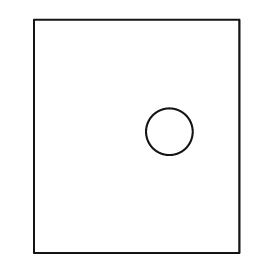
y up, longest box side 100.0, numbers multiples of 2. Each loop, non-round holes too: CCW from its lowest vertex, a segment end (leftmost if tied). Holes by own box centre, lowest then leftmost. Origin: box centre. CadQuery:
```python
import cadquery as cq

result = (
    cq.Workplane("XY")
    .moveTo(-44.0, -50.0)
    .lineTo(44.0, -50.0)
    .lineTo(44.0, 50.0)
    .lineTo(-44.0, 50.0)
    .close()
    .moveTo(14.0, 2.0)
    .circle(10.0)
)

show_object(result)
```